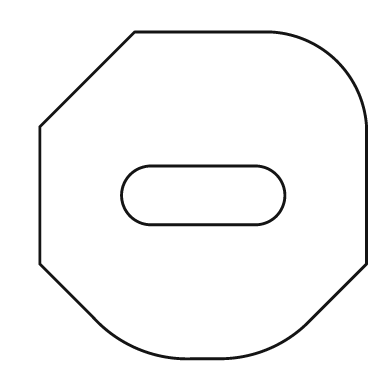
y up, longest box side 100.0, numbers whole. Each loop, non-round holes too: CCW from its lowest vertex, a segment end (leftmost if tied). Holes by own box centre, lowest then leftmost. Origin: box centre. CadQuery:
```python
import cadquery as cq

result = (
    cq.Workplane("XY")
    .moveTo(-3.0, -50.0)
    .lineTo(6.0, -50.0)
    .threePointArc((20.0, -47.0), (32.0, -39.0))
    .lineTo(50.0, -21.0)
    .lineTo(50.0, 21.0)
    .threePointArc((41.0, 41.0), (21.0, 50.0))
    .lineTo(-21.0, 50.0)
    .lineTo(-50.0, 21.0)
    .lineTo(-50.0, -21.0)
    .lineTo(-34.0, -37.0)
    .threePointArc((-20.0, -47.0), (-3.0, -50.0))
    .close()
    .moveTo(-16.0, -9.0)
    .lineTo(16.0, -9.0)
    .threePointArc((25.0, 0.0), (16.0, 9.0))
    .lineTo(-16.0, 9.0)
    .threePointArc((-25.0, 0.0), (-16.0, -9.0))
    .close()
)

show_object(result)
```